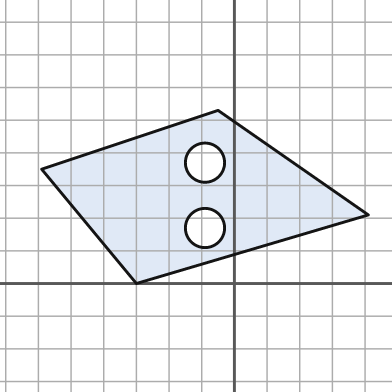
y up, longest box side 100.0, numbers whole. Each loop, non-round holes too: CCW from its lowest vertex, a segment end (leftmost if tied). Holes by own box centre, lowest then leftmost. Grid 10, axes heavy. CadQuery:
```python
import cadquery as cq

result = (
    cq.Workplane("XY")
    .moveTo(-30.0, 0.0)
    .lineTo(41.0, 21.0)
    .lineTo(-5.0, 53.0)
    .lineTo(-59.0, 35.0)
    .close()
    .moveTo(-9.0, 17.0)
    .circle(6.0)
    .moveTo(-9.0, 37.0)
    .circle(6.0)
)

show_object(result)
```